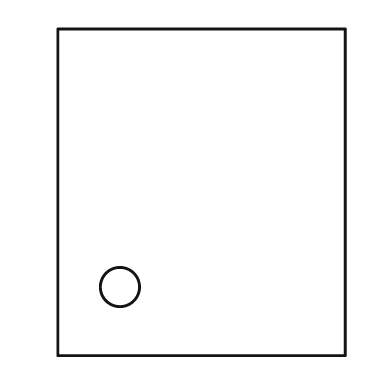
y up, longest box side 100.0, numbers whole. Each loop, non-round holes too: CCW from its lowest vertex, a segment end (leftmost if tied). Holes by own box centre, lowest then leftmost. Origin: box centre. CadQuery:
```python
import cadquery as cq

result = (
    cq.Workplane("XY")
    .moveTo(-44.0, -50.0)
    .lineTo(44.0, -50.0)
    .lineTo(44.0, 50.0)
    .lineTo(-44.0, 50.0)
    .close()
    .moveTo(-25.0, -29.0)
    .circle(6.0)
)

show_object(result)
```